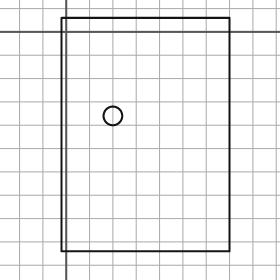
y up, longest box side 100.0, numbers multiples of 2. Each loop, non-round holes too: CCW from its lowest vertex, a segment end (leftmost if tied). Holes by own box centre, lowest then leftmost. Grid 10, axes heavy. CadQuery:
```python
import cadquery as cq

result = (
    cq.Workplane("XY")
    .moveTo(-2.0, -94.0)
    .lineTo(70.0, -94.0)
    .lineTo(70.0, 6.0)
    .lineTo(-2.0, 6.0)
    .close()
    .moveTo(20.0, -36.0)
    .circle(4.0)
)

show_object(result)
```